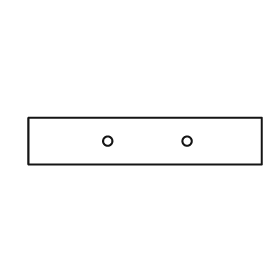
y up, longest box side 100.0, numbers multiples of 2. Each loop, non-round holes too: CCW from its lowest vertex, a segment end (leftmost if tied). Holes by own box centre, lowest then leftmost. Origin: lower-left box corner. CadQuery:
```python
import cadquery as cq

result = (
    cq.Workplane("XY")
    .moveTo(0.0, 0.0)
    .lineTo(100.0, 0.0)
    .lineTo(100.0, 20.0)
    .lineTo(0.0, 20.0)
    .close()
    .moveTo(34.0, 10.0)
    .circle(2.0)
    .moveTo(68.0, 10.0)
    .circle(2.0)
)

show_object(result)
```